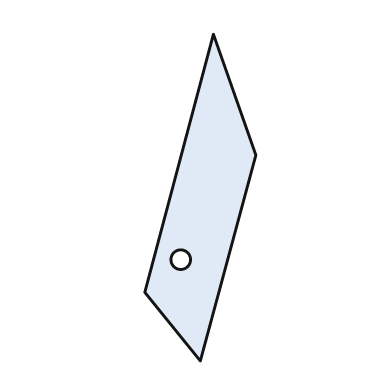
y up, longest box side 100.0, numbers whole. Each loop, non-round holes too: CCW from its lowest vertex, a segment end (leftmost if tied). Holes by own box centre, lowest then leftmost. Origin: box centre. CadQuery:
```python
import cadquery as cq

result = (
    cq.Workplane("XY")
    .moveTo(0.0, -50.0)
    .lineTo(17.0, 13.0)
    .lineTo(4.0, 50.0)
    .lineTo(-17.0, -29.0)
    .close()
    .moveTo(-6.0, -19.0)
    .circle(3.0)
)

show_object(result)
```